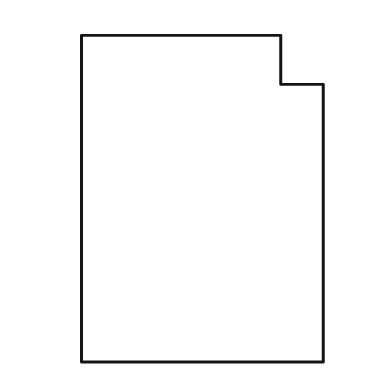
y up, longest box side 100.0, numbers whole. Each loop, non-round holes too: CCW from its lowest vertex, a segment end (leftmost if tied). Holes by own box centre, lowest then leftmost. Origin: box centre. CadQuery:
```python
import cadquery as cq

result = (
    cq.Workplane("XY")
    .moveTo(-37.0, -50.0)
    .lineTo(37.0, -50.0)
    .lineTo(37.0, 35.0)
    .lineTo(24.0, 35.0)
    .lineTo(24.0, 50.0)
    .lineTo(-37.0, 50.0)
    .close()
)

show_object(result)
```